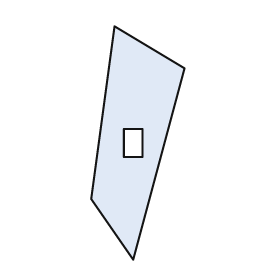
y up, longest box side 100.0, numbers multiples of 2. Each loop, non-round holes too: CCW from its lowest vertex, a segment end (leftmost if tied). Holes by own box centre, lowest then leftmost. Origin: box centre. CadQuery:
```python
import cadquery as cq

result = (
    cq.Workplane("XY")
    .moveTo(-2.0, -50.0)
    .lineTo(20.0, 32.0)
    .lineTo(-10.0, 50.0)
    .lineTo(-20.0, -24.0)
    .close()
    .moveTo(-6.0, -6.0)
    .lineTo(2.0, -6.0)
    .lineTo(2.0, 6.0)
    .lineTo(-6.0, 6.0)
    .close()
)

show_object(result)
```